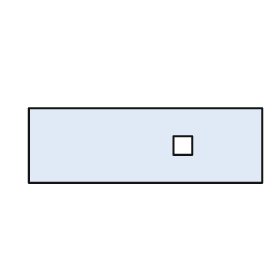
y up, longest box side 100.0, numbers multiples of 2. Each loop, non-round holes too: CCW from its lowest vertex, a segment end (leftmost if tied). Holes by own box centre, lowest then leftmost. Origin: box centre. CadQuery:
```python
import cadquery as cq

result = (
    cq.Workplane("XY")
    .moveTo(-50.0, -16.0)
    .lineTo(50.0, -16.0)
    .lineTo(50.0, 16.0)
    .lineTo(-50.0, 16.0)
    .close()
    .moveTo(12.0, -4.0)
    .lineTo(20.0, -4.0)
    .lineTo(20.0, 4.0)
    .lineTo(12.0, 4.0)
    .close()
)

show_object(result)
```